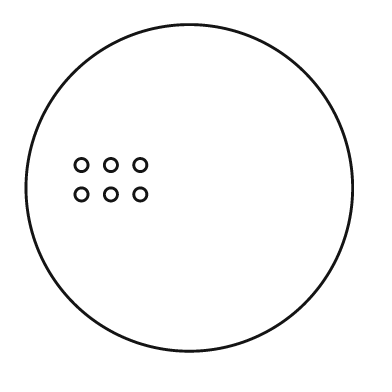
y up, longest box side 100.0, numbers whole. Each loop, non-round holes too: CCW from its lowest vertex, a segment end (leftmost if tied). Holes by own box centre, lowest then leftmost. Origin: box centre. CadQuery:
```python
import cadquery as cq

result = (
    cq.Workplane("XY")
    .moveTo(0.0, 0.0)
    .circle(50.0)
    .moveTo(-33.0, -2.0)
    .circle(2.0)
    .moveTo(-24.0, -2.0)
    .circle(2.0)
    .moveTo(-15.0, -2.0)
    .circle(2.0)
    .moveTo(-33.0, 7.0)
    .circle(2.0)
    .moveTo(-24.0, 7.0)
    .circle(2.0)
    .moveTo(-15.0, 7.0)
    .circle(2.0)
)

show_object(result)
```